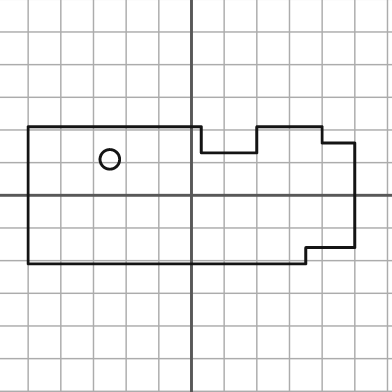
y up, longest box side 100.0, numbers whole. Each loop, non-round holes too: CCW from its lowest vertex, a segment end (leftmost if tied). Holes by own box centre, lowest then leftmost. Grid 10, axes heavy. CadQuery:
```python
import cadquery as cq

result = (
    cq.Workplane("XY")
    .moveTo(-50.0, -21.0)
    .lineTo(35.0, -21.0)
    .lineTo(35.0, -16.0)
    .lineTo(50.0, -16.0)
    .lineTo(50.0, 16.0)
    .lineTo(40.0, 16.0)
    .lineTo(40.0, 21.0)
    .lineTo(20.0, 21.0)
    .lineTo(20.0, 13.0)
    .lineTo(3.0, 13.0)
    .lineTo(3.0, 21.0)
    .lineTo(-50.0, 21.0)
    .close()
    .moveTo(-25.0, 11.0)
    .circle(3.0)
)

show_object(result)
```